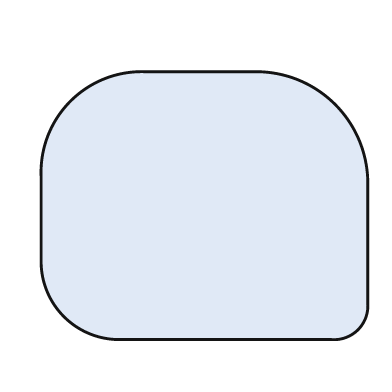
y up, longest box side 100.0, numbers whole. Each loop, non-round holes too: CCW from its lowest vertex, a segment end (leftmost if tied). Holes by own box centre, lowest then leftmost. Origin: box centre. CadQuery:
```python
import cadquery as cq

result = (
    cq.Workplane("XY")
    .moveTo(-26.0, -41.0)
    .lineTo(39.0, -41.0)
    .threePointArc((47.0, -38.0), (50.0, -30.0))
    .lineTo(50.0, 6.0)
    .threePointArc((40.0, 31.0), (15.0, 41.0))
    .lineTo(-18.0, 41.0)
    .threePointArc((-41.0, 32.0), (-50.0, 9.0))
    .lineTo(-50.0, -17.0)
    .threePointArc((-43.0, -34.0), (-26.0, -41.0))
    .close()
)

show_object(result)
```